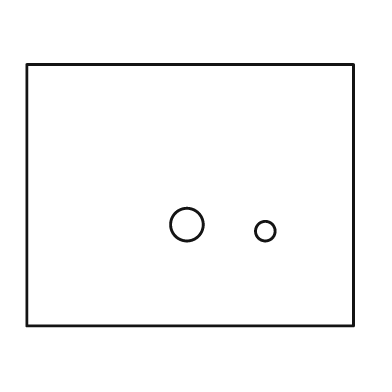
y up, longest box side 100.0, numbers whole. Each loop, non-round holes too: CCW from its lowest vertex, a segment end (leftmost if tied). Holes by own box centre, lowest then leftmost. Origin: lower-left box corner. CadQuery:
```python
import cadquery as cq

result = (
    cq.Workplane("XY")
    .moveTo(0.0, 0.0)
    .lineTo(100.0, 0.0)
    .lineTo(100.0, 80.0)
    .lineTo(0.0, 80.0)
    .close()
    .moveTo(73.0, 29.0)
    .circle(3.0)
    .moveTo(49.0, 31.0)
    .circle(5.0)
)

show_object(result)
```